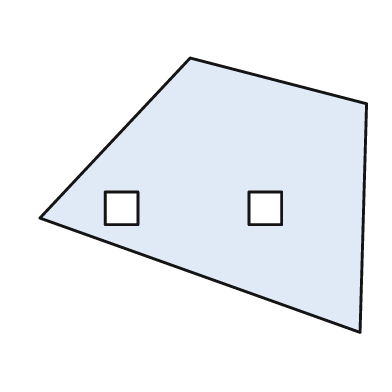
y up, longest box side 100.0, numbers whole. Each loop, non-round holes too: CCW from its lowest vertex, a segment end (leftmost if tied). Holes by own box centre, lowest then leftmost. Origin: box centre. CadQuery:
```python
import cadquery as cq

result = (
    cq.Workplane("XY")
    .moveTo(48.0, -42.0)
    .lineTo(50.0, 28.0)
    .lineTo(-4.0, 42.0)
    .lineTo(-50.0, -7.0)
    .close()
    .moveTo(-30.0, -9.0)
    .lineTo(-20.0, -9.0)
    .lineTo(-20.0, 1.0)
    .lineTo(-30.0, 1.0)
    .close()
    .moveTo(14.0, -9.0)
    .lineTo(24.0, -9.0)
    .lineTo(24.0, 1.0)
    .lineTo(14.0, 1.0)
    .close()
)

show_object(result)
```